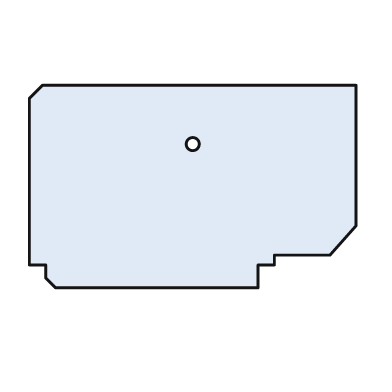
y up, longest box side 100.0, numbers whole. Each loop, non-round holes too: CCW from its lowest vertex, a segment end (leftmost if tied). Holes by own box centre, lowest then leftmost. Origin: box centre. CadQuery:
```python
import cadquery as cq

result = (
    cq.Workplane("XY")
    .moveTo(-42.0, -31.0)
    .lineTo(20.0, -31.0)
    .lineTo(20.0, -24.0)
    .lineTo(25.0, -24.0)
    .lineTo(25.0, -21.0)
    .lineTo(42.0, -21.0)
    .lineTo(50.0, -12.0)
    .lineTo(50.0, 31.0)
    .lineTo(-46.0, 31.0)
    .lineTo(-50.0, 27.0)
    .lineTo(-50.0, -24.0)
    .lineTo(-45.0, -24.0)
    .lineTo(-45.0, -28.0)
    .close()
    .moveTo(0.0, 13.0)
    .circle(2.0)
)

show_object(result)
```